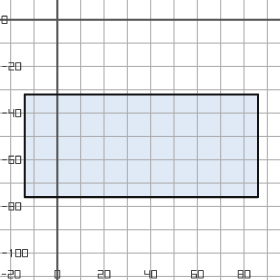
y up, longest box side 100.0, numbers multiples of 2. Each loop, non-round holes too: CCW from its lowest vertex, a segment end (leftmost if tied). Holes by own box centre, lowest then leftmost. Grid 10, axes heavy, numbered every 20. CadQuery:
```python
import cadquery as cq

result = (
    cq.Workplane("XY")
    .moveTo(-14.0, -76.0)
    .lineTo(86.0, -76.0)
    .lineTo(86.0, -32.0)
    .lineTo(-14.0, -32.0)
    .close()
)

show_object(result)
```